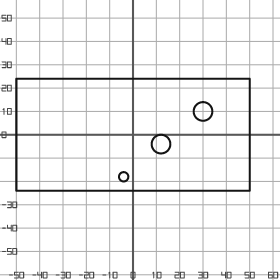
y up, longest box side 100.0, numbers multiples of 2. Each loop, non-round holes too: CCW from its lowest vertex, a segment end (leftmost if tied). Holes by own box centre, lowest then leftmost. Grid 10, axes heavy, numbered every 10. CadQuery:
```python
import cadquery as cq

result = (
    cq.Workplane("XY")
    .moveTo(-50.0, -24.0)
    .lineTo(50.0, -24.0)
    .lineTo(50.0, 24.0)
    .lineTo(-50.0, 24.0)
    .close()
    .moveTo(-4.0, -18.0)
    .circle(2.0)
    .moveTo(12.0, -4.0)
    .circle(4.0)
    .moveTo(30.0, 10.0)
    .circle(4.0)
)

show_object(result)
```